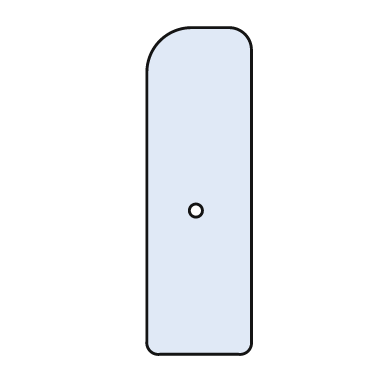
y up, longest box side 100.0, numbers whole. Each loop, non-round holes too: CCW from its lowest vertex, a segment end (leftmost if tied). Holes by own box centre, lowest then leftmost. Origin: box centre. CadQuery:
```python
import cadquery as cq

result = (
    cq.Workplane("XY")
    .moveTo(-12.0, -50.0)
    .lineTo(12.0, -50.0)
    .threePointArc((15.0, -49.0), (16.0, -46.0))
    .lineTo(16.0, 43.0)
    .threePointArc((14.0, 48.0), (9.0, 50.0))
    .lineTo(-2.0, 50.0)
    .threePointArc((-12.0, 46.0), (-16.0, 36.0))
    .lineTo(-16.0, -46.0)
    .threePointArc((-15.0, -49.0), (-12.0, -50.0))
    .close()
    .moveTo(-1.0, -6.0)
    .circle(2.0)
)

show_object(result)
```